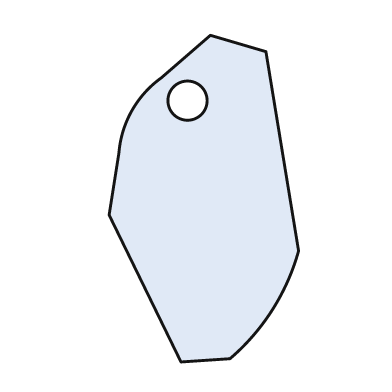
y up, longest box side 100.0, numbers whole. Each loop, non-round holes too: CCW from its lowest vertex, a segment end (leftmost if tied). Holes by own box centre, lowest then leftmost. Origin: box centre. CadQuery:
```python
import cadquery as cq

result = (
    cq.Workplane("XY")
    .moveTo(-7.0, -50.0)
    .lineTo(8.0, -49.0)
    .threePointArc((21.0, -34.0), (29.0, -16.0))
    .lineTo(19.0, 45.0)
    .lineTo(2.0, 50.0)
    .lineTo(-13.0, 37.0)
    .threePointArc((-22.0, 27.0), (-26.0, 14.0))
    .lineTo(-29.0, -5.0)
    .close()
    .moveTo(-5.0, 30.0)
    .circle(6.0)
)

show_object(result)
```